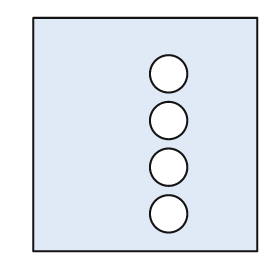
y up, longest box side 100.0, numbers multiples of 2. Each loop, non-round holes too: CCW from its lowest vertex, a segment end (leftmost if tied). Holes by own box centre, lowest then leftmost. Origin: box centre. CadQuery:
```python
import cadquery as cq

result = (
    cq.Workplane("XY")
    .moveTo(-48.0, -50.0)
    .lineTo(48.0, -50.0)
    .lineTo(48.0, 50.0)
    .lineTo(-48.0, 50.0)
    .close()
    .moveTo(10.0, -34.0)
    .circle(8.0)
    .moveTo(10.0, -14.0)
    .circle(8.0)
    .moveTo(10.0, 6.0)
    .circle(8.0)
    .moveTo(10.0, 26.0)
    .circle(8.0)
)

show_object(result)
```